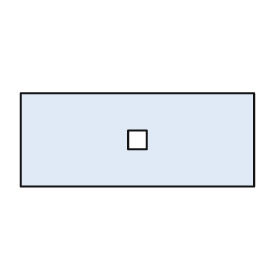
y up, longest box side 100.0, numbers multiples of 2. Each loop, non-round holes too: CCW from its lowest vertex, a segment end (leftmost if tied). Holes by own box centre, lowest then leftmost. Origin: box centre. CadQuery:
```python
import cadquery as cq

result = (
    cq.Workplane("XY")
    .moveTo(-50.0, -20.0)
    .lineTo(50.0, -20.0)
    .lineTo(50.0, 20.0)
    .lineTo(-50.0, 20.0)
    .close()
    .moveTo(-4.0, -4.0)
    .lineTo(4.0, -4.0)
    .lineTo(4.0, 4.0)
    .lineTo(-4.0, 4.0)
    .close()
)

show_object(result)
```